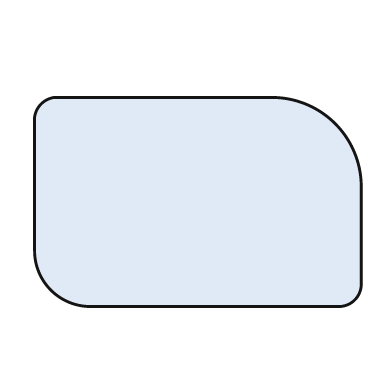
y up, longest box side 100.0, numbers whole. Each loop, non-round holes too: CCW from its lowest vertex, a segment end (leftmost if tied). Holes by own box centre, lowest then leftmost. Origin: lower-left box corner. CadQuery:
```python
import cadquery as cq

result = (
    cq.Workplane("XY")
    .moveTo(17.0, 0.0)
    .lineTo(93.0, 0.0)
    .threePointArc((98.0, 2.0), (100.0, 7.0))
    .lineTo(100.0, 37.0)
    .threePointArc((92.0, 56.0), (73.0, 64.0))
    .lineTo(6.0, 64.0)
    .threePointArc((2.0, 62.0), (0.0, 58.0))
    .lineTo(0.0, 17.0)
    .threePointArc((5.0, 5.0), (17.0, 0.0))
    .close()
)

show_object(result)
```